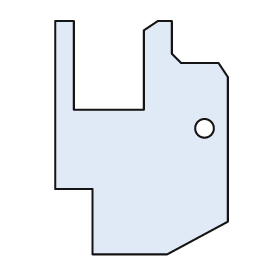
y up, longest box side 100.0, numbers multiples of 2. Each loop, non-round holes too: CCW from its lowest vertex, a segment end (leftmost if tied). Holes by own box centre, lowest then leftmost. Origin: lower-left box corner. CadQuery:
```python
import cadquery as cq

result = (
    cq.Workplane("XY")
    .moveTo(16.0, 0.0)
    .lineTo(48.0, 0.0)
    .lineTo(74.0, 14.0)
    .lineTo(74.0, 76.0)
    .lineTo(70.0, 82.0)
    .lineTo(54.0, 82.0)
    .lineTo(50.0, 86.0)
    .lineTo(50.0, 100.0)
    .lineTo(44.0, 100.0)
    .lineTo(38.0, 96.0)
    .lineTo(38.0, 62.0)
    .lineTo(8.0, 62.0)
    .lineTo(8.0, 100.0)
    .lineTo(0.0, 100.0)
    .lineTo(0.0, 28.0)
    .lineTo(16.0, 28.0)
    .close()
    .moveTo(64.0, 54.0)
    .circle(4.0)
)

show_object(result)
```